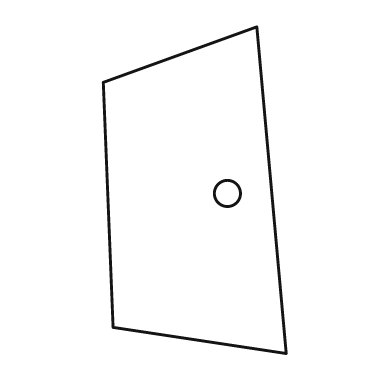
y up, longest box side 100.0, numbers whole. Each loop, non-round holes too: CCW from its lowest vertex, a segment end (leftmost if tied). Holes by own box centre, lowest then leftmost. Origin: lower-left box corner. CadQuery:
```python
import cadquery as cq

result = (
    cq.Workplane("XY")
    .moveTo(56.0, 0.0)
    .lineTo(47.0, 100.0)
    .lineTo(0.0, 83.0)
    .lineTo(3.0, 8.0)
    .close()
    .moveTo(38.0, 49.0)
    .circle(4.0)
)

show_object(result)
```